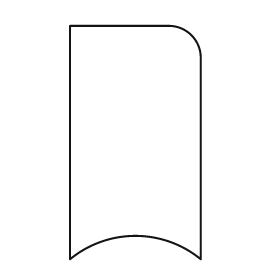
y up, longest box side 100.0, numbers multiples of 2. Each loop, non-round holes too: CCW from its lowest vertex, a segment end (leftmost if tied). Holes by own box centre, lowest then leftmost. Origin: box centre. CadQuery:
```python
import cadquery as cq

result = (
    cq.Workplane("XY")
    .moveTo(-28.0, -50.0)
    .threePointArc((0.0, -40.0), (28.0, -50.0))
    .lineTo(28.0, 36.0)
    .threePointArc((24.0, 46.0), (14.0, 50.0))
    .lineTo(-28.0, 50.0)
    .close()
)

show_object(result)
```